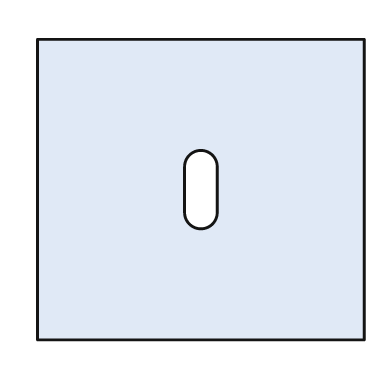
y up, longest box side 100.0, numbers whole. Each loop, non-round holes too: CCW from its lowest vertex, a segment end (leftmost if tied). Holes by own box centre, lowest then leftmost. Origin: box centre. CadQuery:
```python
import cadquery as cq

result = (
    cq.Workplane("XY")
    .moveTo(-50.0, -46.0)
    .lineTo(50.0, -46.0)
    .lineTo(50.0, 46.0)
    .lineTo(-50.0, 46.0)
    .close()
    .moveTo(-5.0, -7.0)
    .threePointArc((0.0, -12.0), (5.0, -7.0))
    .lineTo(5.0, 7.0)
    .threePointArc((0.0, 12.0), (-5.0, 7.0))
    .close()
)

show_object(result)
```